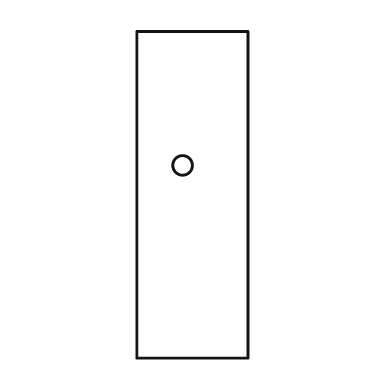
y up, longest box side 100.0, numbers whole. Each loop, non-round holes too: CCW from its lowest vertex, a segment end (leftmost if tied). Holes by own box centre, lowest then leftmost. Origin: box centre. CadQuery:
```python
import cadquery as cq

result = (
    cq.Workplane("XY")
    .moveTo(-17.0, -50.0)
    .lineTo(17.0, -50.0)
    .lineTo(17.0, 50.0)
    .lineTo(-17.0, 50.0)
    .close()
    .moveTo(-3.0, 9.0)
    .circle(3.0)
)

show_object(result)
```